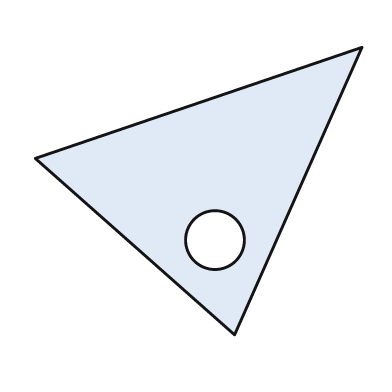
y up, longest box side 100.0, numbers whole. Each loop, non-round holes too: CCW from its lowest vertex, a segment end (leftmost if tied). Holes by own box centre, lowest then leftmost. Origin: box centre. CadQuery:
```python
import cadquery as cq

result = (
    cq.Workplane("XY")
    .moveTo(11.0, -44.0)
    .lineTo(50.0, 44.0)
    .lineTo(-50.0, 10.0)
    .close()
    .moveTo(5.0, -15.0)
    .circle(9.0)
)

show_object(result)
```